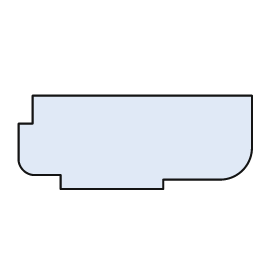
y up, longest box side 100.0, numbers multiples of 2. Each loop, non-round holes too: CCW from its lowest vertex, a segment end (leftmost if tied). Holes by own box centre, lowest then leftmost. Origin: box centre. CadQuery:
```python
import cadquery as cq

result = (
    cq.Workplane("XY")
    .moveTo(-32.0, -20.0)
    .lineTo(12.0, -20.0)
    .lineTo(12.0, -16.0)
    .lineTo(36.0, -16.0)
    .threePointArc((46.0, -12.0), (50.0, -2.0))
    .lineTo(50.0, 20.0)
    .lineTo(-44.0, 20.0)
    .lineTo(-44.0, 8.0)
    .lineTo(-50.0, 8.0)
    .lineTo(-50.0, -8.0)
    .threePointArc((-48.0, -12.0), (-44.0, -14.0))
    .lineTo(-32.0, -14.0)
    .close()
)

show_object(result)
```